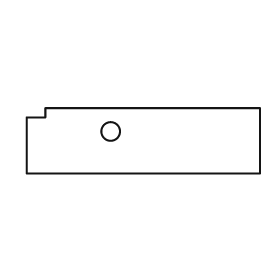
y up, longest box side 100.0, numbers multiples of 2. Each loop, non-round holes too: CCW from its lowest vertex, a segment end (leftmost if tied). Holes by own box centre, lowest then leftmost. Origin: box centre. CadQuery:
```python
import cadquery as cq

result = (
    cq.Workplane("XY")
    .moveTo(-50.0, -14.0)
    .lineTo(50.0, -14.0)
    .lineTo(50.0, 14.0)
    .lineTo(-42.0, 14.0)
    .lineTo(-42.0, 10.0)
    .lineTo(-50.0, 10.0)
    .close()
    .moveTo(-14.0, 4.0)
    .circle(4.0)
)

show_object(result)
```